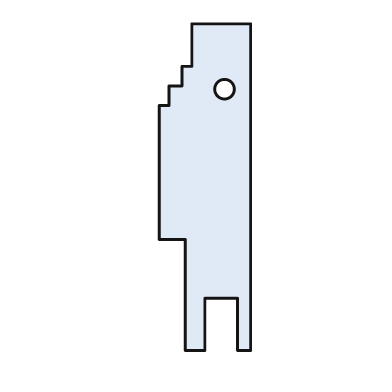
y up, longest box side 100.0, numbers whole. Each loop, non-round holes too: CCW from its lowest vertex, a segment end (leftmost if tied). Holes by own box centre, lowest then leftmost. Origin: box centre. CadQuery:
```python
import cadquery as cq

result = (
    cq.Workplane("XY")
    .moveTo(-6.0, -50.0)
    .lineTo(0.0, -50.0)
    .lineTo(0.0, -34.0)
    .lineTo(10.0, -34.0)
    .lineTo(10.0, -50.0)
    .lineTo(14.0, -50.0)
    .lineTo(14.0, 50.0)
    .lineTo(-4.0, 50.0)
    .lineTo(-4.0, 37.0)
    .lineTo(-7.0, 37.0)
    .lineTo(-7.0, 31.0)
    .lineTo(-11.0, 31.0)
    .lineTo(-11.0, 25.0)
    .lineTo(-14.0, 25.0)
    .lineTo(-14.0, -16.0)
    .lineTo(-6.0, -16.0)
    .close()
    .moveTo(6.0, 30.0)
    .circle(3.0)
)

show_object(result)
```